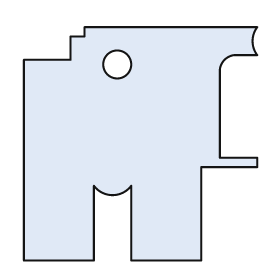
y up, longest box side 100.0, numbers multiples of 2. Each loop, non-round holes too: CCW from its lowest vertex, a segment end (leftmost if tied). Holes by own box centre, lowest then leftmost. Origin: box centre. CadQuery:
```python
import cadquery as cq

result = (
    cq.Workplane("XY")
    .moveTo(-50.0, -50.0)
    .lineTo(-20.0, -50.0)
    .lineTo(-20.0, -18.0)
    .threePointArc((-12.0, -22.0), (-4.0, -18.0))
    .lineTo(-4.0, -50.0)
    .lineTo(26.0, -50.0)
    .lineTo(26.0, -10.0)
    .lineTo(50.0, -10.0)
    .lineTo(50.0, -6.0)
    .lineTo(34.0, -6.0)
    .lineTo(34.0, 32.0)
    .threePointArc((36.0, 36.0), (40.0, 38.0))
    .lineTo(50.0, 38.0)
    .threePointArc((48.0, 44.0), (50.0, 50.0))
    .lineTo(-24.0, 50.0)
    .lineTo(-24.0, 46.0)
    .lineTo(-30.0, 46.0)
    .lineTo(-30.0, 36.0)
    .lineTo(-50.0, 36.0)
    .close()
    .moveTo(-10.0, 34.0)
    .circle(6.0)
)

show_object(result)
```